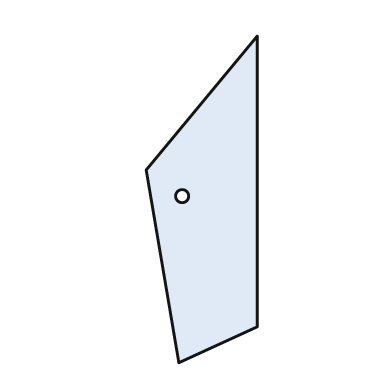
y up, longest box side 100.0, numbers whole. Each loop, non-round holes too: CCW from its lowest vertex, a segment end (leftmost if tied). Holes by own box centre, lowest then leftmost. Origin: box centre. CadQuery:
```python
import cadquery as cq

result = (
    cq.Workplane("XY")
    .moveTo(-7.0, -50.0)
    .lineTo(17.0, -39.0)
    .lineTo(17.0, 50.0)
    .lineTo(-17.0, 9.0)
    .close()
    .moveTo(-6.0, 1.0)
    .circle(2.0)
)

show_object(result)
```